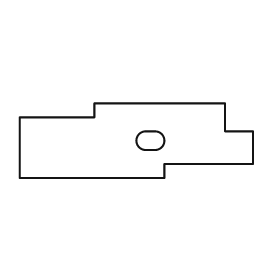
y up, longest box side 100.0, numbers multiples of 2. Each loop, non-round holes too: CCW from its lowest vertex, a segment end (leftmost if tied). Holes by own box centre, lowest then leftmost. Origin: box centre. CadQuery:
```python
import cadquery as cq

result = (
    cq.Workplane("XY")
    .moveTo(-50.0, -16.0)
    .lineTo(12.0, -16.0)
    .lineTo(12.0, -10.0)
    .lineTo(50.0, -10.0)
    .lineTo(50.0, 4.0)
    .lineTo(38.0, 4.0)
    .lineTo(38.0, 16.0)
    .lineTo(-18.0, 16.0)
    .lineTo(-18.0, 10.0)
    .lineTo(-50.0, 10.0)
    .close()
    .moveTo(4.0, -4.0)
    .lineTo(8.0, -4.0)
    .threePointArc((12.0, 0.0), (8.0, 4.0))
    .lineTo(4.0, 4.0)
    .threePointArc((0.0, 0.0), (4.0, -4.0))
    .close()
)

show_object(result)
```